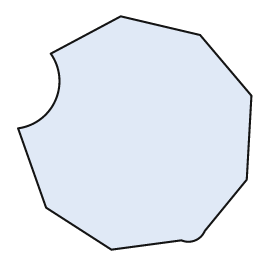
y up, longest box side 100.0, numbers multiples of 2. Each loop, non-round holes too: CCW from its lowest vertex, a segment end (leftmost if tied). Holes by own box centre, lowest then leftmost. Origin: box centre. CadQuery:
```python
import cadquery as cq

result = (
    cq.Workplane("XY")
    .moveTo(-10.0, -50.0)
    .lineTo(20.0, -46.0)
    .threePointArc((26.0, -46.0), (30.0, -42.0))
    .lineTo(48.0, -20.0)
    .lineTo(50.0, 16.0)
    .lineTo(28.0, 42.0)
    .lineTo(-6.0, 50.0)
    .lineTo(-36.0, 34.0)
    .threePointArc((-34.0, 14.0), (-50.0, 2.0))
    .lineTo(-38.0, -32.0)
    .close()
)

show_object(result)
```